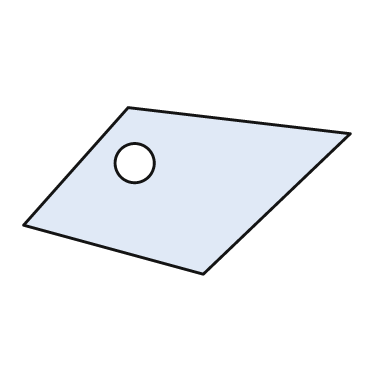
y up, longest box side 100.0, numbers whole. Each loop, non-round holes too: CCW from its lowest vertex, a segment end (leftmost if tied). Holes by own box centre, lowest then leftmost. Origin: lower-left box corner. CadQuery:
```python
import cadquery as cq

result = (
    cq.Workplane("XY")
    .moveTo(55.0, 0.0)
    .lineTo(100.0, 43.0)
    .lineTo(32.0, 51.0)
    .lineTo(0.0, 15.0)
    .close()
    .moveTo(34.0, 34.0)
    .circle(6.0)
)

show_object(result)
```